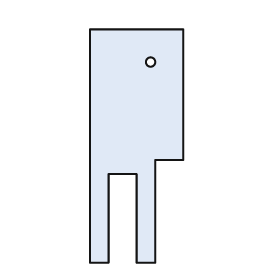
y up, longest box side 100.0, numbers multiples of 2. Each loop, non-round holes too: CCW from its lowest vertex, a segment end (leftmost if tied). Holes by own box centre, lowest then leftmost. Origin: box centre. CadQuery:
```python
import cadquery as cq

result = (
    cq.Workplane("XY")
    .moveTo(-20.0, -50.0)
    .lineTo(-12.0, -50.0)
    .lineTo(-12.0, -12.0)
    .lineTo(0.0, -12.0)
    .lineTo(0.0, -50.0)
    .lineTo(8.0, -50.0)
    .lineTo(8.0, -6.0)
    .lineTo(20.0, -6.0)
    .lineTo(20.0, 50.0)
    .lineTo(-20.0, 50.0)
    .close()
    .moveTo(6.0, 36.0)
    .circle(2.0)
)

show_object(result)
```